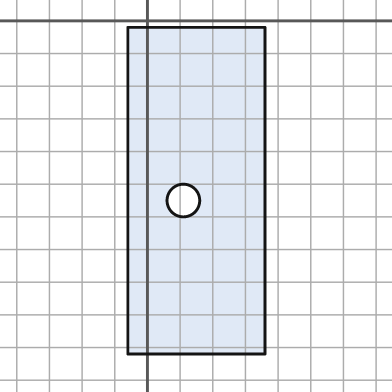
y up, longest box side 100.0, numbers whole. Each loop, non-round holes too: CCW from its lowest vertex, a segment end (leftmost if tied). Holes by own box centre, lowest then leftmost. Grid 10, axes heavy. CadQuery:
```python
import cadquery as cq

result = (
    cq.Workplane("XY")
    .moveTo(-6.0, -102.0)
    .lineTo(36.0, -102.0)
    .lineTo(36.0, -2.0)
    .lineTo(-6.0, -2.0)
    .close()
    .moveTo(11.0, -55.0)
    .circle(5.0)
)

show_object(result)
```